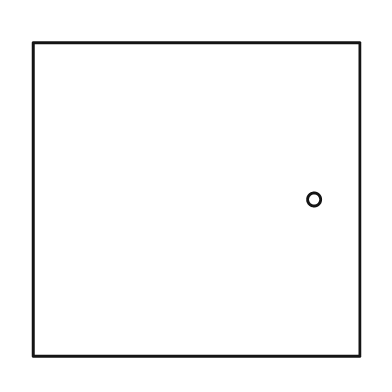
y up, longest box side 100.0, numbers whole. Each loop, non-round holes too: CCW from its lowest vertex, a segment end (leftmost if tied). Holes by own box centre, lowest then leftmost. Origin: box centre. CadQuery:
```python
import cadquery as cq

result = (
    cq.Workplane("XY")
    .moveTo(-50.0, -48.0)
    .lineTo(50.0, -48.0)
    .lineTo(50.0, 48.0)
    .lineTo(-50.0, 48.0)
    .close()
    .moveTo(36.0, 0.0)
    .circle(2.0)
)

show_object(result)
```